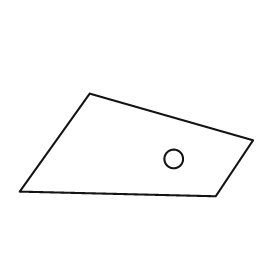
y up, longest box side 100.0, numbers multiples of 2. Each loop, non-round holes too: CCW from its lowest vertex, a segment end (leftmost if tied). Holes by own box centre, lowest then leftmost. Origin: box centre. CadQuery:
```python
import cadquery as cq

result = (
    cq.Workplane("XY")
    .moveTo(34.0, -22.0)
    .lineTo(50.0, 2.0)
    .lineTo(-20.0, 22.0)
    .lineTo(-50.0, -20.0)
    .close()
    .moveTo(16.0, -6.0)
    .circle(4.0)
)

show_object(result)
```